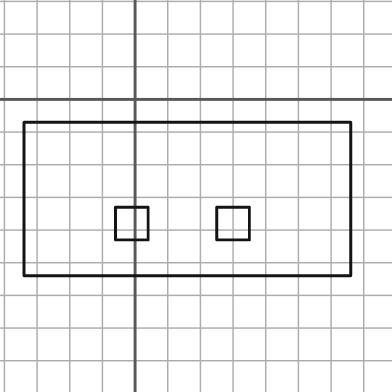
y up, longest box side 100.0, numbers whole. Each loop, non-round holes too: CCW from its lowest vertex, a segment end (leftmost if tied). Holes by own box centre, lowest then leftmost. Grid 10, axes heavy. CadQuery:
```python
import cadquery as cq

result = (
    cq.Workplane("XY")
    .moveTo(-34.0, -54.0)
    .lineTo(66.0, -54.0)
    .lineTo(66.0, -7.0)
    .lineTo(-34.0, -7.0)
    .close()
    .moveTo(-6.0, -43.0)
    .lineTo(4.0, -43.0)
    .lineTo(4.0, -33.0)
    .lineTo(-6.0, -33.0)
    .close()
    .moveTo(25.0, -43.0)
    .lineTo(35.0, -43.0)
    .lineTo(35.0, -33.0)
    .lineTo(25.0, -33.0)
    .close()
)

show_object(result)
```